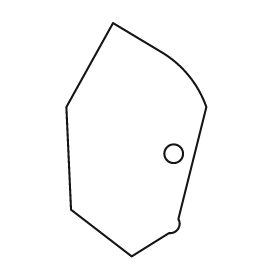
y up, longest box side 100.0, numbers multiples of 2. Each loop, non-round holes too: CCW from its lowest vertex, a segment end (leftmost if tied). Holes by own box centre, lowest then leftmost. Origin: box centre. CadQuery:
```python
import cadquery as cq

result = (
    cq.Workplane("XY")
    .moveTo(-2.0, -50.0)
    .lineTo(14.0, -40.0)
    .threePointArc((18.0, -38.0), (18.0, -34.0))
    .lineTo(30.0, 14.0)
    .threePointArc((22.0, 28.0), (10.0, 38.0))
    .lineTo(-10.0, 50.0)
    .lineTo(-30.0, 14.0)
    .lineTo(-28.0, -30.0)
    .close()
    .moveTo(16.0, -6.0)
    .circle(4.0)
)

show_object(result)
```